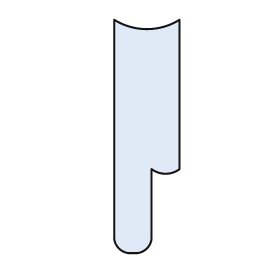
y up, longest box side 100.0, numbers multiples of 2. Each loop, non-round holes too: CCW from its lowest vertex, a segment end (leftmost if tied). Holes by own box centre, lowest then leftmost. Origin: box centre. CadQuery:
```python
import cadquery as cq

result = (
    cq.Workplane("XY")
    .moveTo(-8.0, -50.0)
    .lineTo(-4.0, -50.0)
    .threePointArc((0.0, -48.0), (2.0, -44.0))
    .lineTo(2.0, -14.0)
    .threePointArc((8.0, -16.0), (14.0, -14.0))
    .lineTo(14.0, 50.0)
    .threePointArc((0.0, 46.0), (-14.0, 50.0))
    .lineTo(-14.0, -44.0)
    .threePointArc((-12.0, -48.0), (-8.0, -50.0))
    .close()
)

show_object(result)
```